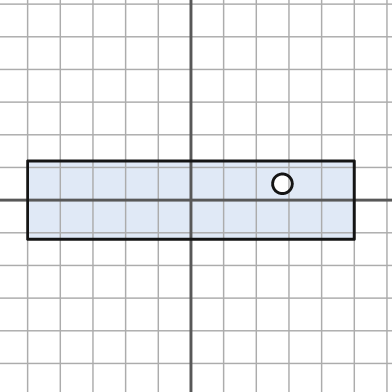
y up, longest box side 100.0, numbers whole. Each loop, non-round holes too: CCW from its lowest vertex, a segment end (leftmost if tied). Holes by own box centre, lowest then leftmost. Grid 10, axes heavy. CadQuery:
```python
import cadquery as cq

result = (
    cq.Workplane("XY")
    .moveTo(-50.0, -12.0)
    .lineTo(50.0, -12.0)
    .lineTo(50.0, 12.0)
    .lineTo(-50.0, 12.0)
    .close()
    .moveTo(28.0, 5.0)
    .circle(3.0)
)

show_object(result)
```